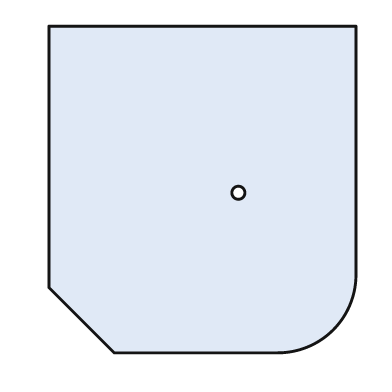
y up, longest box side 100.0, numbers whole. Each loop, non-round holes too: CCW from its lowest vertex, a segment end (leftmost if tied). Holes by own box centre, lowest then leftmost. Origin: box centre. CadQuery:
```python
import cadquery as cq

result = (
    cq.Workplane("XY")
    .moveTo(-27.0, -50.0)
    .lineTo(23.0, -50.0)
    .threePointArc((40.0, -43.0), (47.0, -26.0))
    .lineTo(47.0, 50.0)
    .lineTo(-47.0, 50.0)
    .lineTo(-47.0, -30.0)
    .close()
    .moveTo(11.0, -1.0)
    .circle(2.0)
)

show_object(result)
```